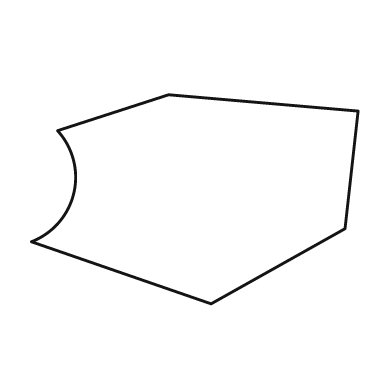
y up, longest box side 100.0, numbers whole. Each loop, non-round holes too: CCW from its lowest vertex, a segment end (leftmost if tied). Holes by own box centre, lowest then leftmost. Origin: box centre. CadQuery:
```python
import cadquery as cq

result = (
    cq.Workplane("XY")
    .moveTo(5.0, -32.0)
    .lineTo(46.0, -9.0)
    .lineTo(50.0, 27.0)
    .lineTo(-8.0, 32.0)
    .lineTo(-42.0, 21.0)
    .threePointArc((-37.0, 2.0), (-50.0, -13.0))
    .close()
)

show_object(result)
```